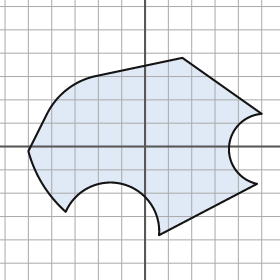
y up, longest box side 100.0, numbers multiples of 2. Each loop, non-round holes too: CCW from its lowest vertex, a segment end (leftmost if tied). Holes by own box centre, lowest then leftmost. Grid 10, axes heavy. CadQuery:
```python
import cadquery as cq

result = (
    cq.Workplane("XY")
    .moveTo(6.0, -38.0)
    .lineTo(48.0, -16.0)
    .threePointArc((36.0, 0.0), (50.0, 14.0))
    .lineTo(16.0, 38.0)
    .lineTo(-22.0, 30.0)
    .threePointArc((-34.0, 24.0), (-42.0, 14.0))
    .lineTo(-50.0, -2.0)
    .threePointArc((-44.0, -16.0), (-34.0, -28.0))
    .threePointArc((-10.0, -16.0), (6.0, -38.0))
    .close()
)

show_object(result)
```